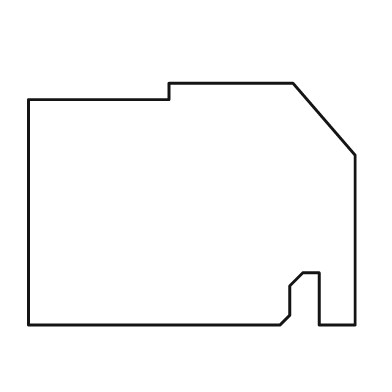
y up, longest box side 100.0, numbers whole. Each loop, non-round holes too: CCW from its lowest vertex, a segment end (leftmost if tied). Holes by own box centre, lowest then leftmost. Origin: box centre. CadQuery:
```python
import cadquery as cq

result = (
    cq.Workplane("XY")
    .moveTo(-50.0, -37.0)
    .lineTo(27.0, -37.0)
    .lineTo(30.0, -34.0)
    .lineTo(30.0, -25.0)
    .lineTo(34.0, -21.0)
    .lineTo(39.0, -21.0)
    .lineTo(39.0, -37.0)
    .lineTo(50.0, -37.0)
    .lineTo(50.0, 15.0)
    .lineTo(31.0, 37.0)
    .lineTo(-7.0, 37.0)
    .lineTo(-7.0, 32.0)
    .lineTo(-50.0, 32.0)
    .close()
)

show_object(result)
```